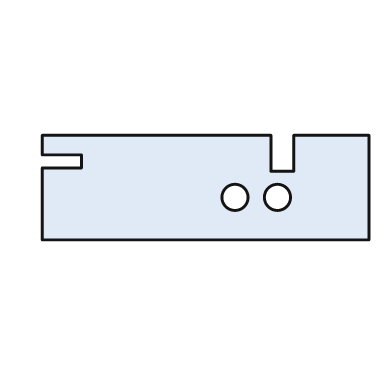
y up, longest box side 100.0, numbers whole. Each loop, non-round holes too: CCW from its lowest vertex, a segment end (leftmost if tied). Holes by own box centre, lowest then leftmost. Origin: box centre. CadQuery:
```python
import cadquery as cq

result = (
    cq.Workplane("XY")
    .moveTo(-50.0, -16.0)
    .lineTo(50.0, -16.0)
    .lineTo(50.0, 16.0)
    .lineTo(27.0, 16.0)
    .lineTo(27.0, 5.0)
    .lineTo(20.0, 5.0)
    .lineTo(20.0, 16.0)
    .lineTo(-50.0, 16.0)
    .lineTo(-50.0, 10.0)
    .lineTo(-38.0, 10.0)
    .lineTo(-38.0, 6.0)
    .lineTo(-50.0, 6.0)
    .close()
    .moveTo(9.0, -3.0)
    .circle(4.0)
    .moveTo(22.0, -3.0)
    .circle(4.0)
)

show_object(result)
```